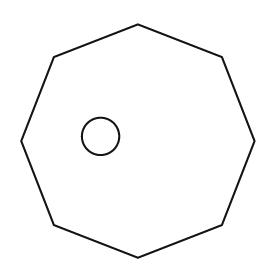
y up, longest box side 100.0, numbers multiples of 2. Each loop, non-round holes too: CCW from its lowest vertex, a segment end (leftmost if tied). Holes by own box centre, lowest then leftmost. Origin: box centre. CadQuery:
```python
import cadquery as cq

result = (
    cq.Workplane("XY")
    .moveTo(0.0, -50.0)
    .lineTo(36.0, -36.0)
    .lineTo(50.0, 0.0)
    .lineTo(36.0, 36.0)
    .lineTo(0.0, 50.0)
    .lineTo(-36.0, 36.0)
    .lineTo(-50.0, 0.0)
    .lineTo(-36.0, -36.0)
    .close()
    .moveTo(-16.0, 2.0)
    .circle(8.0)
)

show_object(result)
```